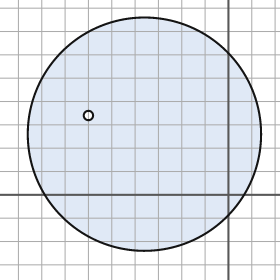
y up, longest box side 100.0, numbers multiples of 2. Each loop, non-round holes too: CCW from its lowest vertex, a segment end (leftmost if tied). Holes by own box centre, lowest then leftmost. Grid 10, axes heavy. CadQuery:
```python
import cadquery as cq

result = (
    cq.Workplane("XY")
    .moveTo(-36.0, 26.0)
    .circle(50.0)
    .moveTo(-60.0, 34.0)
    .circle(2.0)
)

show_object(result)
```